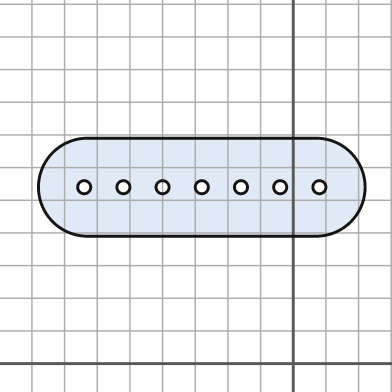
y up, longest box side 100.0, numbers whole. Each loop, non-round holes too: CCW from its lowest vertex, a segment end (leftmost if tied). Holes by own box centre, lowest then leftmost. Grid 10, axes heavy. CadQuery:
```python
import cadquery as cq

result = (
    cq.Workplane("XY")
    .moveTo(-63.0, 39.0)
    .lineTo(7.0, 39.0)
    .threePointArc((22.0, 54.0), (7.0, 69.0))
    .lineTo(-63.0, 69.0)
    .threePointArc((-78.0, 54.0), (-63.0, 39.0))
    .close()
    .moveTo(-64.0, 54.0)
    .circle(2.0)
    .moveTo(-52.0, 54.0)
    .circle(2.0)
    .moveTo(-40.0, 54.0)
    .circle(2.0)
    .moveTo(-28.0, 54.0)
    .circle(2.0)
    .moveTo(-16.0, 54.0)
    .circle(2.0)
    .moveTo(-4.0, 54.0)
    .circle(2.0)
    .moveTo(8.0, 54.0)
    .circle(2.0)
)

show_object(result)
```